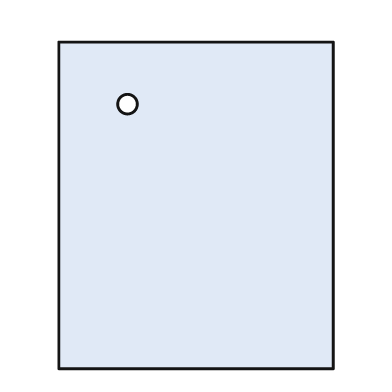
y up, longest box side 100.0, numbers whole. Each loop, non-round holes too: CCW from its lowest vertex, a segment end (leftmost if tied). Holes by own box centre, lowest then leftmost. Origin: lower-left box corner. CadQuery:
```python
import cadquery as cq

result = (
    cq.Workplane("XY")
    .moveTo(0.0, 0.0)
    .lineTo(84.0, 0.0)
    .lineTo(84.0, 100.0)
    .lineTo(0.0, 100.0)
    .close()
    .moveTo(21.0, 81.0)
    .circle(3.0)
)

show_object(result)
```